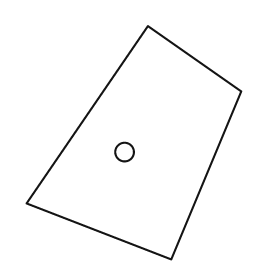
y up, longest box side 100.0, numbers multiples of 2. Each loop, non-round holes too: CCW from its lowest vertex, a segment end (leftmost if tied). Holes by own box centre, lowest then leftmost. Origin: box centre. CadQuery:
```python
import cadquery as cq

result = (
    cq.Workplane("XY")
    .moveTo(16.0, -50.0)
    .lineTo(46.0, 22.0)
    .lineTo(6.0, 50.0)
    .lineTo(-46.0, -26.0)
    .close()
    .moveTo(-4.0, -4.0)
    .circle(4.0)
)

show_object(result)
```